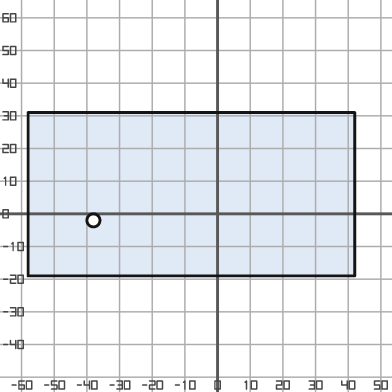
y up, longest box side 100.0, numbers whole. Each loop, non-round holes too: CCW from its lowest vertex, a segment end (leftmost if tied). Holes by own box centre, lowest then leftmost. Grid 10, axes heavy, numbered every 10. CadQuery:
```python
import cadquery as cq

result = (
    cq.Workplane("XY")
    .moveTo(-58.0, -19.0)
    .lineTo(42.0, -19.0)
    .lineTo(42.0, 31.0)
    .lineTo(-58.0, 31.0)
    .close()
    .moveTo(-38.0, -2.0)
    .circle(2.0)
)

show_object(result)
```